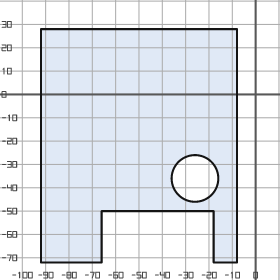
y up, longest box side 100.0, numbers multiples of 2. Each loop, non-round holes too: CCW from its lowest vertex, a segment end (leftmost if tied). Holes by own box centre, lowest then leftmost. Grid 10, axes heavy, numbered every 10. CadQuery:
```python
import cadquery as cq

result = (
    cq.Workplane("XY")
    .moveTo(-92.0, -72.0)
    .lineTo(-66.0, -72.0)
    .lineTo(-66.0, -50.0)
    .lineTo(-18.0, -50.0)
    .lineTo(-18.0, -72.0)
    .lineTo(-8.0, -72.0)
    .lineTo(-8.0, 28.0)
    .lineTo(-92.0, 28.0)
    .close()
    .moveTo(-26.0, -36.0)
    .circle(10.0)
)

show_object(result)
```